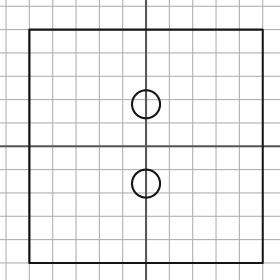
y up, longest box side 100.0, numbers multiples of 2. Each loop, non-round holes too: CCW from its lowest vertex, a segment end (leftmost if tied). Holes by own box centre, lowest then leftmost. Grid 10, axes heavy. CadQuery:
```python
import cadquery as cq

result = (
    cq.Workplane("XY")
    .moveTo(-50.0, -50.0)
    .lineTo(50.0, -50.0)
    .lineTo(50.0, 50.0)
    .lineTo(-50.0, 50.0)
    .close()
    .moveTo(0.0, -16.0)
    .circle(6.0)
    .moveTo(0.0, 18.0)
    .circle(6.0)
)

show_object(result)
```